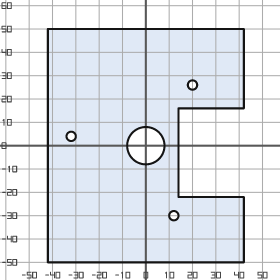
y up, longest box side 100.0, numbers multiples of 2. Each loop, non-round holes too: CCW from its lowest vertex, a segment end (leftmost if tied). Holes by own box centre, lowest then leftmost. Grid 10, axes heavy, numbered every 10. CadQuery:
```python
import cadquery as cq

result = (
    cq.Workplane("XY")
    .moveTo(-42.0, -50.0)
    .lineTo(42.0, -50.0)
    .lineTo(42.0, -22.0)
    .lineTo(14.0, -22.0)
    .lineTo(14.0, 16.0)
    .lineTo(42.0, 16.0)
    .lineTo(42.0, 50.0)
    .lineTo(-42.0, 50.0)
    .close()
    .moveTo(12.0, -30.0)
    .circle(2.0)
    .moveTo(0.0, 0.0)
    .circle(8.0)
    .moveTo(-32.0, 4.0)
    .circle(2.0)
    .moveTo(20.0, 26.0)
    .circle(2.0)
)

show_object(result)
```